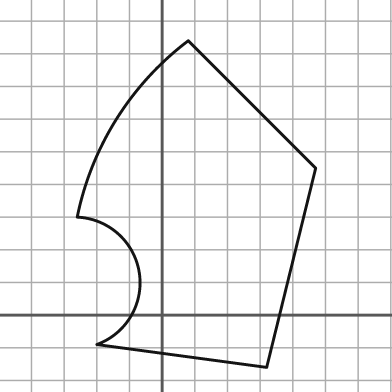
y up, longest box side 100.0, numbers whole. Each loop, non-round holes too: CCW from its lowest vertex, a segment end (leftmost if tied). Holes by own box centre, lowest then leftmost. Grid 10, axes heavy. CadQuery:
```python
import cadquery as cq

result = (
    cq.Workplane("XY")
    .moveTo(32.0, -16.0)
    .lineTo(47.0, 45.0)
    .lineTo(8.0, 84.0)
    .threePointArc((-14.0, 60.0), (-26.0, 30.0))
    .threePointArc((-7.0, 13.0), (-20.0, -9.0))
    .close()
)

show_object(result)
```